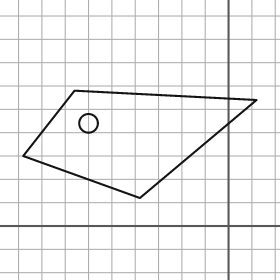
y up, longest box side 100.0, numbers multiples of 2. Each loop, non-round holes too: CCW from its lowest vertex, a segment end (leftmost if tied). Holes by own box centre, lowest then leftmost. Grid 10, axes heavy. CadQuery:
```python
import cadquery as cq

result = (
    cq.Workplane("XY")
    .moveTo(-38.0, 12.0)
    .lineTo(12.0, 54.0)
    .lineTo(-66.0, 58.0)
    .lineTo(-88.0, 30.0)
    .close()
    .moveTo(-60.0, 44.0)
    .circle(4.0)
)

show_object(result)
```